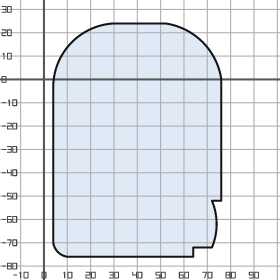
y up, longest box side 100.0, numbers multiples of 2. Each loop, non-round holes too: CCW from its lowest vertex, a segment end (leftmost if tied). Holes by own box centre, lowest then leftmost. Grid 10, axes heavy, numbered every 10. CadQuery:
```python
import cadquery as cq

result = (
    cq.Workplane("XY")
    .moveTo(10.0, -76.0)
    .lineTo(64.0, -76.0)
    .lineTo(64.0, -72.0)
    .lineTo(72.0, -72.0)
    .threePointArc((74.0, -62.0), (72.0, -52.0))
    .lineTo(76.0, -52.0)
    .lineTo(76.0, 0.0)
    .threePointArc((68.0, 16.0), (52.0, 24.0))
    .lineTo(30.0, 24.0)
    .threePointArc((12.0, 16.0), (4.0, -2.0))
    .lineTo(4.0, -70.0)
    .threePointArc((6.0, -74.0), (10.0, -76.0))
    .close()
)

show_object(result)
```